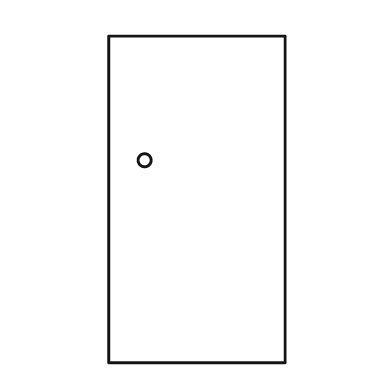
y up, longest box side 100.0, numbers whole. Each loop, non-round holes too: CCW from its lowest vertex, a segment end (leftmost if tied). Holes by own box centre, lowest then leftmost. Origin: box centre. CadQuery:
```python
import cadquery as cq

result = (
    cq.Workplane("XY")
    .moveTo(-27.0, -50.0)
    .lineTo(27.0, -50.0)
    .lineTo(27.0, 50.0)
    .lineTo(-27.0, 50.0)
    .close()
    .moveTo(-16.0, 12.0)
    .circle(2.0)
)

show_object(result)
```